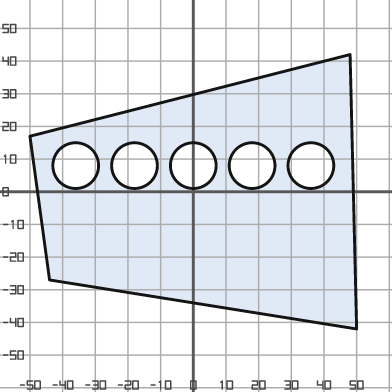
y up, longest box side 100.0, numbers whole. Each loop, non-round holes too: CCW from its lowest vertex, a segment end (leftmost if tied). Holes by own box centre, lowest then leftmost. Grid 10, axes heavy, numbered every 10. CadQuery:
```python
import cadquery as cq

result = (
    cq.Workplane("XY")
    .moveTo(50.0, -42.0)
    .lineTo(48.0, 42.0)
    .lineTo(-50.0, 17.0)
    .lineTo(-44.0, -27.0)
    .close()
    .moveTo(-36.0, 8.0)
    .circle(7.0)
    .moveTo(-18.0, 8.0)
    .circle(7.0)
    .moveTo(0.0, 8.0)
    .circle(7.0)
    .moveTo(18.0, 8.0)
    .circle(7.0)
    .moveTo(36.0, 8.0)
    .circle(7.0)
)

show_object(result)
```